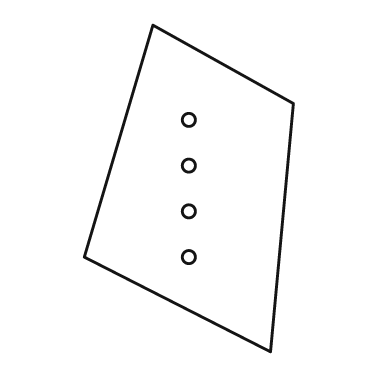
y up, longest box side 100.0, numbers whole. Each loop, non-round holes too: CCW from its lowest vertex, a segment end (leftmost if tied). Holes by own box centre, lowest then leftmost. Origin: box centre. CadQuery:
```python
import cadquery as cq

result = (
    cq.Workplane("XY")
    .moveTo(25.0, -50.0)
    .lineTo(32.0, 26.0)
    .lineTo(-11.0, 50.0)
    .lineTo(-32.0, -21.0)
    .close()
    .moveTo(0.0, -21.0)
    .circle(2.0)
    .moveTo(0.0, -7.0)
    .circle(2.0)
    .moveTo(0.0, 7.0)
    .circle(2.0)
    .moveTo(0.0, 21.0)
    .circle(2.0)
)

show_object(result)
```